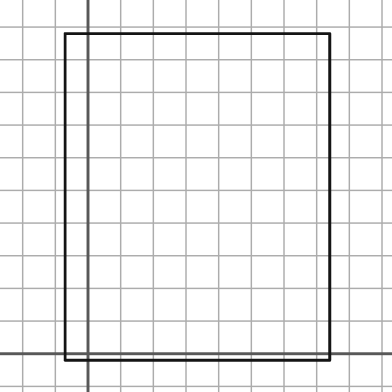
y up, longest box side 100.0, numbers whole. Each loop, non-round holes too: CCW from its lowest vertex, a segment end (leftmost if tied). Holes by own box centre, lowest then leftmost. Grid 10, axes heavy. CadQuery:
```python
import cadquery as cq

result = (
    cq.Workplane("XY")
    .moveTo(-7.0, -2.0)
    .lineTo(74.0, -2.0)
    .lineTo(74.0, 98.0)
    .lineTo(-7.0, 98.0)
    .close()
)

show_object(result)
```